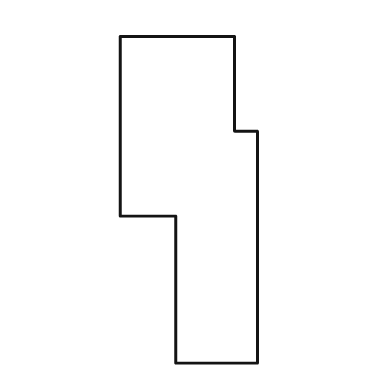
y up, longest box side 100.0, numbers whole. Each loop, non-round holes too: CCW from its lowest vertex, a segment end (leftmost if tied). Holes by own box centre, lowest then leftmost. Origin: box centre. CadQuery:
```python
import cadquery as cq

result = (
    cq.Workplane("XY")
    .moveTo(-4.0, -50.0)
    .lineTo(21.0, -50.0)
    .lineTo(21.0, 21.0)
    .lineTo(14.0, 21.0)
    .lineTo(14.0, 50.0)
    .lineTo(-21.0, 50.0)
    .lineTo(-21.0, -5.0)
    .lineTo(-4.0, -5.0)
    .close()
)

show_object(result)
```